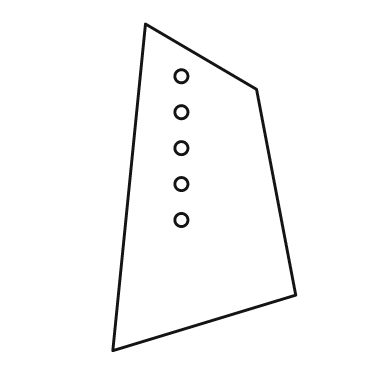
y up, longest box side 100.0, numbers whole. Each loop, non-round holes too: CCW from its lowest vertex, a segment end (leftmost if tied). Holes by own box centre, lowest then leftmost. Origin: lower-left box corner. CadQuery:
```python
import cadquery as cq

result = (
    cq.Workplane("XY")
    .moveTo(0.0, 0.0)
    .lineTo(56.0, 17.0)
    .lineTo(44.0, 80.0)
    .lineTo(10.0, 100.0)
    .close()
    .moveTo(21.0, 40.0)
    .circle(2.0)
    .moveTo(21.0, 51.0)
    .circle(2.0)
    .moveTo(21.0, 62.0)
    .circle(2.0)
    .moveTo(21.0, 73.0)
    .circle(2.0)
    .moveTo(21.0, 84.0)
    .circle(2.0)
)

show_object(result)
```